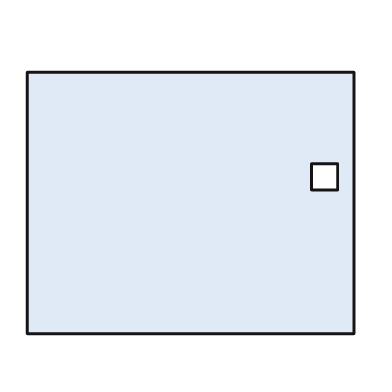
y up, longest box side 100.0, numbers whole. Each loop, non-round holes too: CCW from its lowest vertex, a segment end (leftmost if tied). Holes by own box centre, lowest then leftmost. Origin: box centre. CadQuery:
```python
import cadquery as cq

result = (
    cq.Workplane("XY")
    .moveTo(-50.0, -40.0)
    .lineTo(50.0, -40.0)
    .lineTo(50.0, 40.0)
    .lineTo(-50.0, 40.0)
    .close()
    .moveTo(37.0, 4.0)
    .lineTo(45.0, 4.0)
    .lineTo(45.0, 12.0)
    .lineTo(37.0, 12.0)
    .close()
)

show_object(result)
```